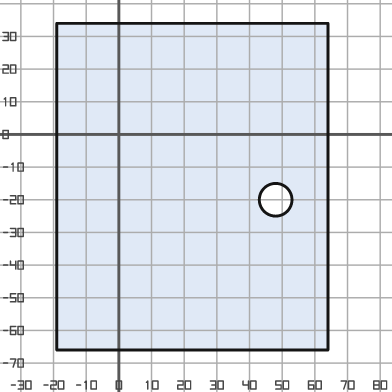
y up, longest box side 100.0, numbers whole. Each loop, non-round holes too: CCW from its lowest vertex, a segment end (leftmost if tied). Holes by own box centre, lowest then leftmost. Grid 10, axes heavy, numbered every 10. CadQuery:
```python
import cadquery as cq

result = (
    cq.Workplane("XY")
    .moveTo(-19.0, -66.0)
    .lineTo(64.0, -66.0)
    .lineTo(64.0, 34.0)
    .lineTo(-19.0, 34.0)
    .close()
    .moveTo(48.0, -20.0)
    .circle(5.0)
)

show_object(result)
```